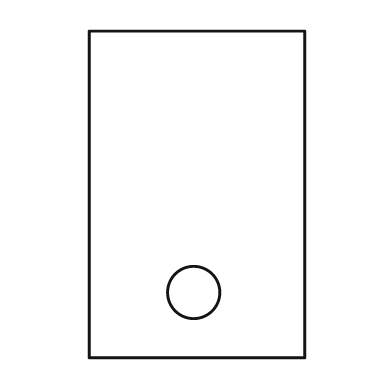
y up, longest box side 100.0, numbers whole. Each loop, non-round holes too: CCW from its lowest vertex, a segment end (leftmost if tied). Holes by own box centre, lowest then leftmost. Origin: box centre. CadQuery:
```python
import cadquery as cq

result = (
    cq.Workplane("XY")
    .moveTo(-33.0, -50.0)
    .lineTo(33.0, -50.0)
    .lineTo(33.0, 50.0)
    .lineTo(-33.0, 50.0)
    .close()
    .moveTo(-1.0, -30.0)
    .circle(8.0)
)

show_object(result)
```